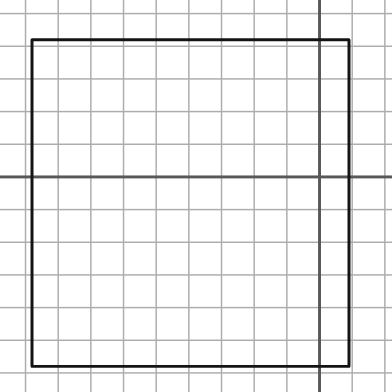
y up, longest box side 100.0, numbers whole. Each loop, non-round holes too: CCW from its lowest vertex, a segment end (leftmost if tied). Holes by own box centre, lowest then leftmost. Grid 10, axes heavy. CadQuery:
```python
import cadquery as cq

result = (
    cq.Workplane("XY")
    .moveTo(-88.0, -58.0)
    .lineTo(9.0, -58.0)
    .lineTo(9.0, 42.0)
    .lineTo(-88.0, 42.0)
    .close()
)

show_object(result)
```